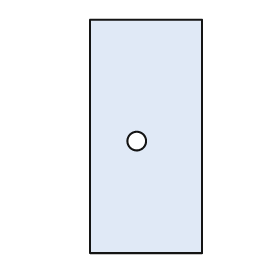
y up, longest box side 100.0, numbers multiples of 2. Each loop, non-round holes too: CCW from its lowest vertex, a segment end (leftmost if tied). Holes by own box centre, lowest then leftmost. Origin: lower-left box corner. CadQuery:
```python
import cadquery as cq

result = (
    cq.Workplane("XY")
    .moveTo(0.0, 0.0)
    .lineTo(48.0, 0.0)
    .lineTo(48.0, 100.0)
    .lineTo(0.0, 100.0)
    .close()
    .moveTo(20.0, 48.0)
    .circle(4.0)
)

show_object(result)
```